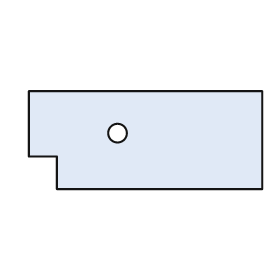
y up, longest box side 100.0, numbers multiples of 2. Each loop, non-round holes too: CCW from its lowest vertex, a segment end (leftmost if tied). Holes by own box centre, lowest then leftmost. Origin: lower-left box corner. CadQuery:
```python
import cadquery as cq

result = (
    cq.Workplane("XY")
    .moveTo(12.0, 0.0)
    .lineTo(100.0, 0.0)
    .lineTo(100.0, 42.0)
    .lineTo(0.0, 42.0)
    .lineTo(0.0, 14.0)
    .lineTo(12.0, 14.0)
    .close()
    .moveTo(38.0, 24.0)
    .circle(4.0)
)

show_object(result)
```